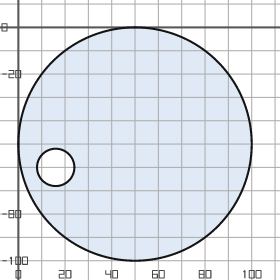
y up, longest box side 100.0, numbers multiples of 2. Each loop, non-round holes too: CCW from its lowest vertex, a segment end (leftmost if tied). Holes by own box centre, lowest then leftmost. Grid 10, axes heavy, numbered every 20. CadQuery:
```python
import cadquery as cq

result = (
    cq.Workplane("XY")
    .moveTo(50.0, -50.0)
    .circle(50.0)
    .moveTo(16.0, -60.0)
    .circle(8.0)
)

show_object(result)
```